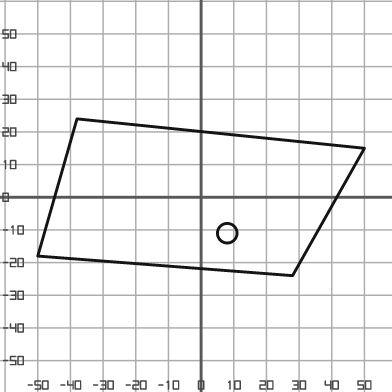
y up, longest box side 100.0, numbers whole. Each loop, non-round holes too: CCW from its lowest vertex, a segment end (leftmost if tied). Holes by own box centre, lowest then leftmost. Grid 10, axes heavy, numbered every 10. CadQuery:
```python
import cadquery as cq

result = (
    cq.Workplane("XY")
    .moveTo(28.0, -24.0)
    .lineTo(50.0, 15.0)
    .lineTo(-38.0, 24.0)
    .lineTo(-50.0, -18.0)
    .close()
    .moveTo(8.0, -11.0)
    .circle(3.0)
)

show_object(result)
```